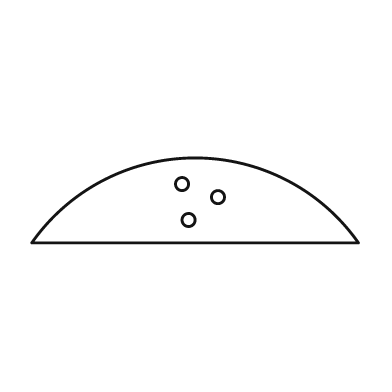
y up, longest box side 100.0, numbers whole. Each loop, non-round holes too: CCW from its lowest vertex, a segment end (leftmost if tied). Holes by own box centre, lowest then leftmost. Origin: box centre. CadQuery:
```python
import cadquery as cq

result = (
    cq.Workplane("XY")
    .moveTo(-50.0, -13.0)
    .lineTo(50.0, -13.0)
    .threePointArc((0.0, 13.0), (-50.0, -13.0))
    .close()
    .moveTo(-2.0, -6.0)
    .circle(2.0)
    .moveTo(7.0, 1.0)
    .circle(2.0)
    .moveTo(-4.0, 5.0)
    .circle(2.0)
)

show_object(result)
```